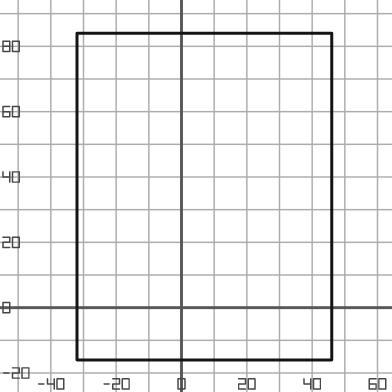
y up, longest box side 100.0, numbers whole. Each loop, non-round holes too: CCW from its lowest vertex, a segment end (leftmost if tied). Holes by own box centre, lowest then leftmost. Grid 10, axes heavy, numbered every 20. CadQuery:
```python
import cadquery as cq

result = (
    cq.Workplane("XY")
    .moveTo(-32.0, -16.0)
    .lineTo(46.0, -16.0)
    .lineTo(46.0, 84.0)
    .lineTo(-32.0, 84.0)
    .close()
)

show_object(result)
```